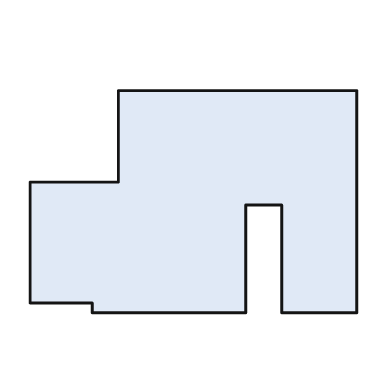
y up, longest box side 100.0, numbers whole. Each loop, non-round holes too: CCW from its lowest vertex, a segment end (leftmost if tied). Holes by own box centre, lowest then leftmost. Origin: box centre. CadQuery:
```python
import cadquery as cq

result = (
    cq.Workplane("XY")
    .moveTo(-31.0, -34.0)
    .lineTo(16.0, -34.0)
    .lineTo(16.0, -1.0)
    .lineTo(27.0, -1.0)
    .lineTo(27.0, -34.0)
    .lineTo(50.0, -34.0)
    .lineTo(50.0, 34.0)
    .lineTo(-23.0, 34.0)
    .lineTo(-23.0, 6.0)
    .lineTo(-50.0, 6.0)
    .lineTo(-50.0, -31.0)
    .lineTo(-31.0, -31.0)
    .close()
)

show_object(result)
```